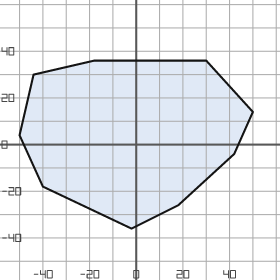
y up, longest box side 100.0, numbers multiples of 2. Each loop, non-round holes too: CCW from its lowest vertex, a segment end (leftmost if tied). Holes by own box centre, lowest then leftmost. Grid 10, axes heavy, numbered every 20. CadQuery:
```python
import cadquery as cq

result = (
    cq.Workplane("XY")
    .moveTo(-2.0, -36.0)
    .lineTo(18.0, -26.0)
    .lineTo(42.0, -4.0)
    .lineTo(50.0, 14.0)
    .lineTo(30.0, 36.0)
    .lineTo(-18.0, 36.0)
    .lineTo(-44.0, 30.0)
    .lineTo(-50.0, 4.0)
    .lineTo(-40.0, -18.0)
    .close()
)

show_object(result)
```